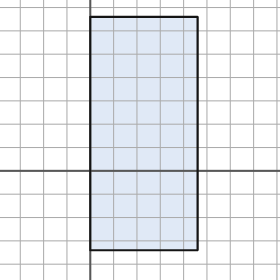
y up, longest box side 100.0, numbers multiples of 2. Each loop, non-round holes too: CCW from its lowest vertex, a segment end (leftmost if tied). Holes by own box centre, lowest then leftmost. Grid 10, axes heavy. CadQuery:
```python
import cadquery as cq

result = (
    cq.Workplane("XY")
    .moveTo(0.0, -34.0)
    .lineTo(46.0, -34.0)
    .lineTo(46.0, 66.0)
    .lineTo(0.0, 66.0)
    .close()
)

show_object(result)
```